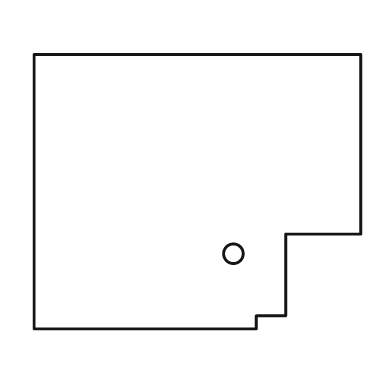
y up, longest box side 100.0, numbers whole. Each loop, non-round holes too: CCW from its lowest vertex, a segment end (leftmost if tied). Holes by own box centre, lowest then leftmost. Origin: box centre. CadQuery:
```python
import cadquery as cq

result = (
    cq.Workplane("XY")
    .moveTo(-50.0, -42.0)
    .lineTo(18.0, -42.0)
    .lineTo(18.0, -38.0)
    .lineTo(27.0, -38.0)
    .lineTo(27.0, -13.0)
    .lineTo(50.0, -13.0)
    .lineTo(50.0, 42.0)
    .lineTo(-50.0, 42.0)
    .close()
    .moveTo(11.0, -19.0)
    .circle(3.0)
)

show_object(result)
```